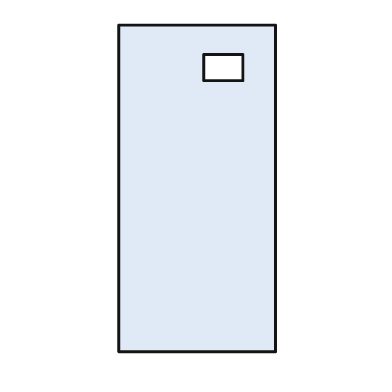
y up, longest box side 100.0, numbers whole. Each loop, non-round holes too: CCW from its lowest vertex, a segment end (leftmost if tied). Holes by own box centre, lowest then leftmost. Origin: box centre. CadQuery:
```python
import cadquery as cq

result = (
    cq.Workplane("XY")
    .moveTo(-24.0, -50.0)
    .lineTo(24.0, -50.0)
    .lineTo(24.0, 50.0)
    .lineTo(-24.0, 50.0)
    .close()
    .moveTo(2.0, 33.0)
    .lineTo(14.0, 33.0)
    .lineTo(14.0, 41.0)
    .lineTo(2.0, 41.0)
    .close()
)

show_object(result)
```